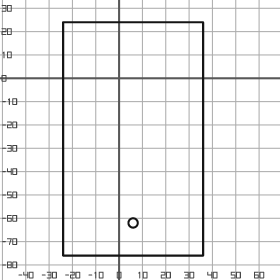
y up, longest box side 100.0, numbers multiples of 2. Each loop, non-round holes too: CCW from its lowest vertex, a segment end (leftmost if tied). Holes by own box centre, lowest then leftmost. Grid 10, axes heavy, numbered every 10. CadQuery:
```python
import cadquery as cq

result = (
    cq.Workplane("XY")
    .moveTo(-24.0, -76.0)
    .lineTo(36.0, -76.0)
    .lineTo(36.0, 24.0)
    .lineTo(-24.0, 24.0)
    .close()
    .moveTo(6.0, -62.0)
    .circle(2.0)
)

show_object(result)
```